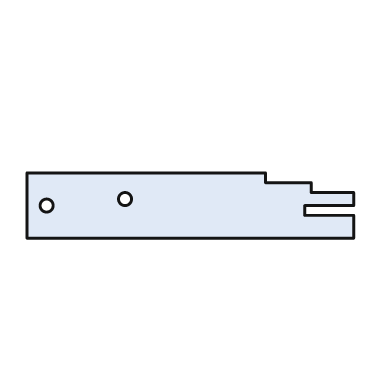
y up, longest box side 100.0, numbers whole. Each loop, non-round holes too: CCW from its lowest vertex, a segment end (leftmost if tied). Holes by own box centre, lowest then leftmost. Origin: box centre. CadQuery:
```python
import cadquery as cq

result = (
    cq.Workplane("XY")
    .moveTo(-50.0, -10.0)
    .lineTo(50.0, -10.0)
    .lineTo(50.0, -3.0)
    .lineTo(35.0, -3.0)
    .lineTo(35.0, 0.0)
    .lineTo(50.0, 0.0)
    .lineTo(50.0, 4.0)
    .lineTo(37.0, 4.0)
    .lineTo(37.0, 7.0)
    .lineTo(23.0, 7.0)
    .lineTo(23.0, 10.0)
    .lineTo(-50.0, 10.0)
    .close()
    .moveTo(-44.0, 0.0)
    .circle(2.0)
    .moveTo(-20.0, 2.0)
    .circle(2.0)
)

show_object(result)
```